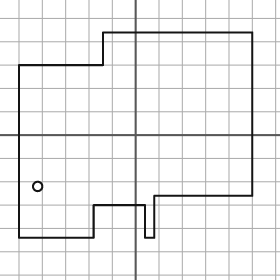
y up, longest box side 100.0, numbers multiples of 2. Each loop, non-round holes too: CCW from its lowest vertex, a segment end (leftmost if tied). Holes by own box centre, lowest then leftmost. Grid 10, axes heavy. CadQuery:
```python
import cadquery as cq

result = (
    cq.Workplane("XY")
    .moveTo(-50.0, -44.0)
    .lineTo(-18.0, -44.0)
    .lineTo(-18.0, -30.0)
    .lineTo(4.0, -30.0)
    .lineTo(4.0, -44.0)
    .lineTo(8.0, -44.0)
    .lineTo(8.0, -26.0)
    .lineTo(50.0, -26.0)
    .lineTo(50.0, 44.0)
    .lineTo(-14.0, 44.0)
    .lineTo(-14.0, 30.0)
    .lineTo(-50.0, 30.0)
    .close()
    .moveTo(-42.0, -22.0)
    .circle(2.0)
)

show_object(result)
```